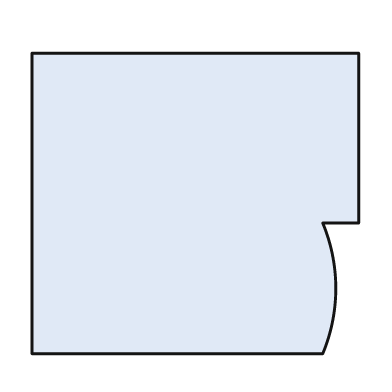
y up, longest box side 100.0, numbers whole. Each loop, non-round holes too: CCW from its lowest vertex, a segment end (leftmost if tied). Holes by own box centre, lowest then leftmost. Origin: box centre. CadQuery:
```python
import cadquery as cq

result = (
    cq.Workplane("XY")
    .moveTo(-50.0, -46.0)
    .lineTo(39.0, -46.0)
    .threePointArc((43.0, -26.0), (39.0, -6.0))
    .lineTo(50.0, -6.0)
    .lineTo(50.0, 46.0)
    .lineTo(-50.0, 46.0)
    .close()
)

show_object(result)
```